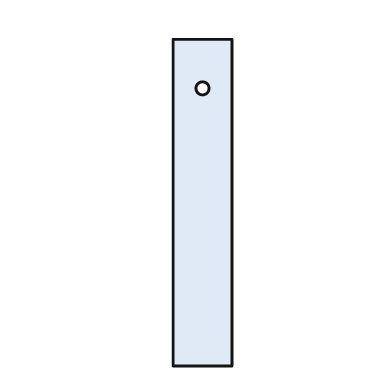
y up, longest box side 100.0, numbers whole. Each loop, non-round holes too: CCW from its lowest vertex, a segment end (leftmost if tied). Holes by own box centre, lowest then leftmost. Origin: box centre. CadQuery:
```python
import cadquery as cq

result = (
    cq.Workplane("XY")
    .moveTo(-9.0, -50.0)
    .lineTo(9.0, -50.0)
    .lineTo(9.0, 50.0)
    .lineTo(-9.0, 50.0)
    .close()
    .moveTo(0.0, 35.0)
    .circle(2.0)
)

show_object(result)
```